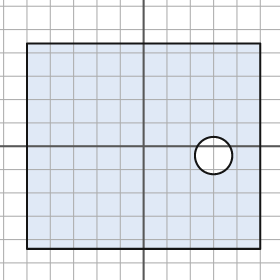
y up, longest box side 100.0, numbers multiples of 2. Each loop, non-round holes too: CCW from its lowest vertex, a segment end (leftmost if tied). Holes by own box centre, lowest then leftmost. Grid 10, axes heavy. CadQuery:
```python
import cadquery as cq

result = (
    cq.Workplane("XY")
    .moveTo(-50.0, -44.0)
    .lineTo(50.0, -44.0)
    .lineTo(50.0, 44.0)
    .lineTo(-50.0, 44.0)
    .close()
    .moveTo(30.0, -4.0)
    .circle(8.0)
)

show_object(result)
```